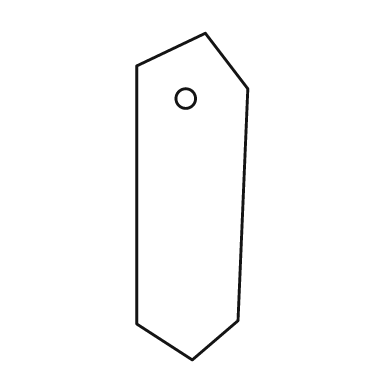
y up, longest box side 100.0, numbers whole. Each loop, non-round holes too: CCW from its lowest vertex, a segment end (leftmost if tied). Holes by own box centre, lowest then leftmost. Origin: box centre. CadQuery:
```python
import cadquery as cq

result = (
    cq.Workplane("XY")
    .moveTo(0.0, -50.0)
    .lineTo(14.0, -38.0)
    .lineTo(17.0, 33.0)
    .lineTo(4.0, 50.0)
    .lineTo(-17.0, 40.0)
    .lineTo(-17.0, -39.0)
    .close()
    .moveTo(-2.0, 30.0)
    .circle(3.0)
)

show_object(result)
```